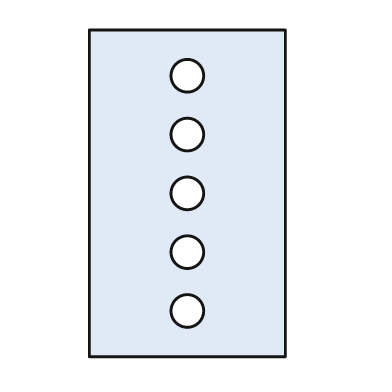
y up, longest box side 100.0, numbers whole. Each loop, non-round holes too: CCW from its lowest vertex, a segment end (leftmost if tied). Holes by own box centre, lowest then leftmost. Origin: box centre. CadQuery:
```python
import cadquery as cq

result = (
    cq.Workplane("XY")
    .moveTo(-30.0, -50.0)
    .lineTo(30.0, -50.0)
    .lineTo(30.0, 50.0)
    .lineTo(-30.0, 50.0)
    .close()
    .moveTo(0.0, -36.0)
    .circle(5.0)
    .moveTo(0.0, -18.0)
    .circle(5.0)
    .moveTo(0.0, 0.0)
    .circle(5.0)
    .moveTo(0.0, 18.0)
    .circle(5.0)
    .moveTo(0.0, 36.0)
    .circle(5.0)
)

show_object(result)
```